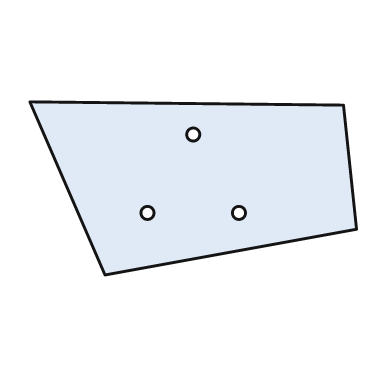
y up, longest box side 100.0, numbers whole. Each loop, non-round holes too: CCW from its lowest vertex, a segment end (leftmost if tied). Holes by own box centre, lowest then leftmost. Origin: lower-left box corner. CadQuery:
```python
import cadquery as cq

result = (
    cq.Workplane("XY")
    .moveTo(23.0, 0.0)
    .lineTo(100.0, 14.0)
    .lineTo(96.0, 52.0)
    .lineTo(0.0, 53.0)
    .close()
    .moveTo(36.0, 19.0)
    .circle(2.0)
    .moveTo(64.0, 19.0)
    .circle(2.0)
    .moveTo(50.0, 43.0)
    .circle(2.0)
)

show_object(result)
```